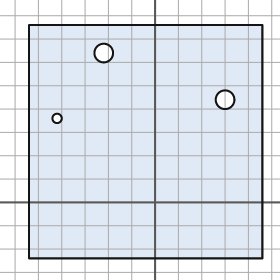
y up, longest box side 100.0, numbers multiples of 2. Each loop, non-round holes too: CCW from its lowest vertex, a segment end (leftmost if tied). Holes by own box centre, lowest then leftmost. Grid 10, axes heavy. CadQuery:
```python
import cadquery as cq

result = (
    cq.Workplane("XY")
    .moveTo(-54.0, -24.0)
    .lineTo(46.0, -24.0)
    .lineTo(46.0, 76.0)
    .lineTo(-54.0, 76.0)
    .close()
    .moveTo(-42.0, 36.0)
    .circle(2.0)
    .moveTo(30.0, 44.0)
    .circle(4.0)
    .moveTo(-22.0, 64.0)
    .circle(4.0)
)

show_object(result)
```